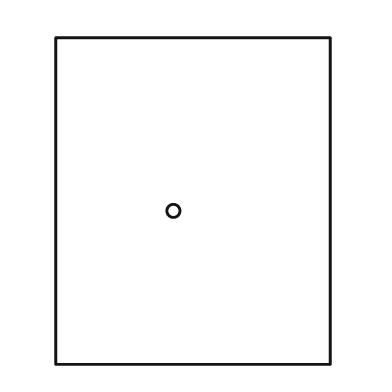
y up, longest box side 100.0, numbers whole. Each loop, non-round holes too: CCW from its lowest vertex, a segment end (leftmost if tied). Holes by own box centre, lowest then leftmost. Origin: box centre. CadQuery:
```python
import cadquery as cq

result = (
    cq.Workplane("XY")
    .moveTo(-42.0, -50.0)
    .lineTo(42.0, -50.0)
    .lineTo(42.0, 50.0)
    .lineTo(-42.0, 50.0)
    .close()
    .moveTo(-6.0, -3.0)
    .circle(2.0)
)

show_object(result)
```